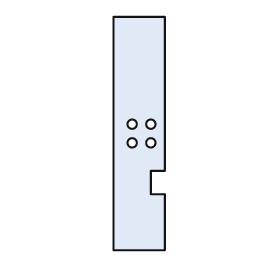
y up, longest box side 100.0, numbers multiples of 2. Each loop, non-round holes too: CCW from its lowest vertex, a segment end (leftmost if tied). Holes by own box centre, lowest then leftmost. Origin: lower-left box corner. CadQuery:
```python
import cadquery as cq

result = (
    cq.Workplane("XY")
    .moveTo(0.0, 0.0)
    .lineTo(22.0, 0.0)
    .lineTo(22.0, 24.0)
    .lineTo(16.0, 24.0)
    .lineTo(16.0, 34.0)
    .lineTo(22.0, 34.0)
    .lineTo(22.0, 100.0)
    .lineTo(0.0, 100.0)
    .close()
    .moveTo(8.0, 46.0)
    .circle(2.0)
    .moveTo(16.0, 46.0)
    .circle(2.0)
    .moveTo(8.0, 54.0)
    .circle(2.0)
    .moveTo(16.0, 54.0)
    .circle(2.0)
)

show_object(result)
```